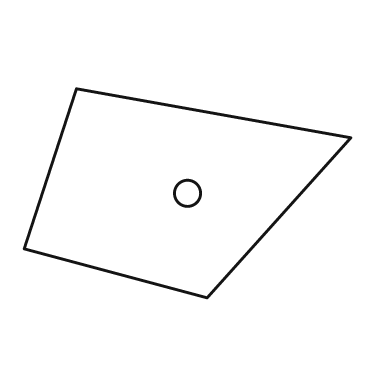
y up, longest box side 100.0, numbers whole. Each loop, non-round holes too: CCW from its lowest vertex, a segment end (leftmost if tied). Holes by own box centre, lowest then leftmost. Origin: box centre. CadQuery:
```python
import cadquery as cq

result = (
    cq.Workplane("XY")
    .moveTo(6.0, -32.0)
    .lineTo(50.0, 17.0)
    .lineTo(-34.0, 32.0)
    .lineTo(-50.0, -17.0)
    .close()
    .moveTo(0.0, 0.0)
    .circle(4.0)
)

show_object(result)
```